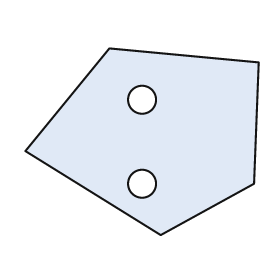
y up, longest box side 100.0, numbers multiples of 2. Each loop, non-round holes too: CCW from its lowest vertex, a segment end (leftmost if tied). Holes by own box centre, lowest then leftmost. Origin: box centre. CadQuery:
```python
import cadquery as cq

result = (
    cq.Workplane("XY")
    .moveTo(8.0, -40.0)
    .lineTo(48.0, -18.0)
    .lineTo(50.0, 34.0)
    .lineTo(-14.0, 40.0)
    .lineTo(-50.0, -4.0)
    .close()
    .moveTo(0.0, -18.0)
    .circle(6.0)
    .moveTo(0.0, 18.0)
    .circle(6.0)
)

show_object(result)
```